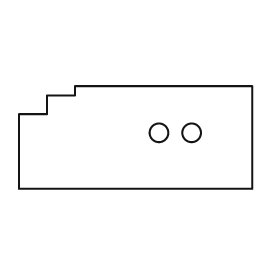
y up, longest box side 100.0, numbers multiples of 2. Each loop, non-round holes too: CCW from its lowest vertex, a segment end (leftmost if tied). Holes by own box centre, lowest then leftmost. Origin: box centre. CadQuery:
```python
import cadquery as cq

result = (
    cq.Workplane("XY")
    .moveTo(-50.0, -22.0)
    .lineTo(50.0, -22.0)
    .lineTo(50.0, 22.0)
    .lineTo(-26.0, 22.0)
    .lineTo(-26.0, 18.0)
    .lineTo(-38.0, 18.0)
    .lineTo(-38.0, 10.0)
    .lineTo(-50.0, 10.0)
    .close()
    .moveTo(10.0, 2.0)
    .circle(4.0)
    .moveTo(24.0, 2.0)
    .circle(4.0)
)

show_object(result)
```